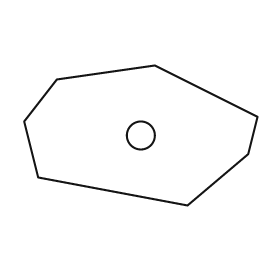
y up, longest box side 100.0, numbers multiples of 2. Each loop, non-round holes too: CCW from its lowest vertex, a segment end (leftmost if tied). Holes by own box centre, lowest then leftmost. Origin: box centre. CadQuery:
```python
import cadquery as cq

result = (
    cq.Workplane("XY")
    .moveTo(20.0, -30.0)
    .lineTo(46.0, -8.0)
    .lineTo(50.0, 8.0)
    .lineTo(6.0, 30.0)
    .lineTo(-36.0, 24.0)
    .lineTo(-50.0, 6.0)
    .lineTo(-44.0, -18.0)
    .close()
    .moveTo(0.0, 0.0)
    .circle(6.0)
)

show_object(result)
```